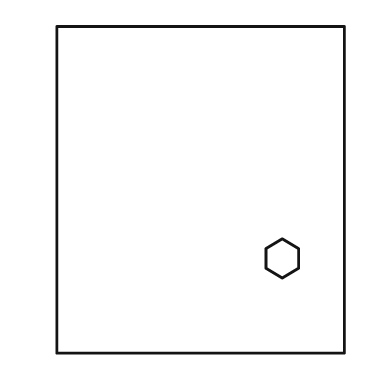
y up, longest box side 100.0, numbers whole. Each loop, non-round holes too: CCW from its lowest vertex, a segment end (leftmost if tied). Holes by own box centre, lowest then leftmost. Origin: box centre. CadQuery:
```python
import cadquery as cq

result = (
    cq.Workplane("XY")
    .moveTo(-44.0, -50.0)
    .lineTo(44.0, -50.0)
    .lineTo(44.0, 50.0)
    .lineTo(-44.0, 50.0)
    .close()
    .moveTo(25.0, -27.0)
    .lineTo(30.0, -24.0)
    .lineTo(30.0, -18.0)
    .lineTo(25.0, -15.0)
    .lineTo(20.0, -18.0)
    .lineTo(20.0, -24.0)
    .close()
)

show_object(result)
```